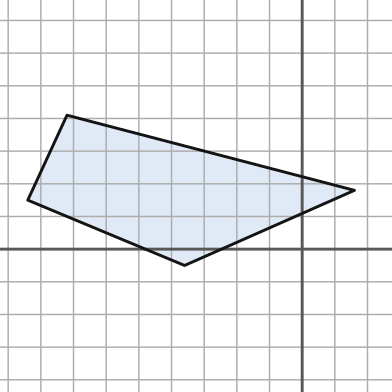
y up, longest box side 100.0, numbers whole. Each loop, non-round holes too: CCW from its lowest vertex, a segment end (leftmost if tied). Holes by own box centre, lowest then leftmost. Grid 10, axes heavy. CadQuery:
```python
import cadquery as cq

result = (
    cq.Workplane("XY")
    .moveTo(-36.0, -5.0)
    .lineTo(16.0, 18.0)
    .lineTo(-72.0, 41.0)
    .lineTo(-84.0, 15.0)
    .close()
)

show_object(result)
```